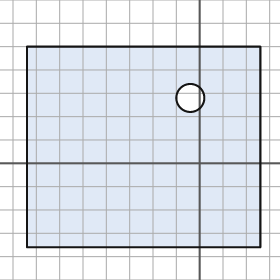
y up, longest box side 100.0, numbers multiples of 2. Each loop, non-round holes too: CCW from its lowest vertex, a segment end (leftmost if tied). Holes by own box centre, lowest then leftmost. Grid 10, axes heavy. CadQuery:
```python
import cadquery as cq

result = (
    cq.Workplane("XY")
    .moveTo(-74.0, -36.0)
    .lineTo(26.0, -36.0)
    .lineTo(26.0, 50.0)
    .lineTo(-74.0, 50.0)
    .close()
    .moveTo(-4.0, 28.0)
    .circle(6.0)
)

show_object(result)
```